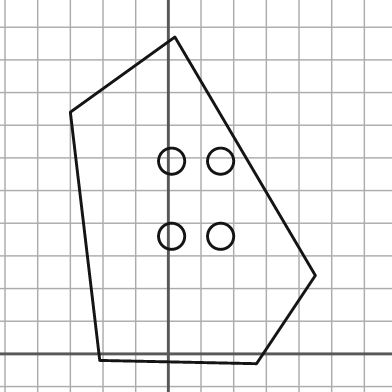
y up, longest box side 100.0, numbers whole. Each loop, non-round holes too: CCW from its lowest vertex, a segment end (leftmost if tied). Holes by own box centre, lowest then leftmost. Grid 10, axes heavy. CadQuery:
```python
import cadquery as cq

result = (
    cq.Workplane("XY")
    .moveTo(27.0, -3.0)
    .lineTo(45.0, 24.0)
    .lineTo(2.0, 97.0)
    .lineTo(-30.0, 74.0)
    .lineTo(-21.0, -2.0)
    .close()
    .moveTo(1.0, 36.0)
    .circle(4.0)
    .moveTo(16.0, 36.0)
    .circle(4.0)
    .moveTo(1.0, 59.0)
    .circle(4.0)
    .moveTo(16.0, 59.0)
    .circle(4.0)
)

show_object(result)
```